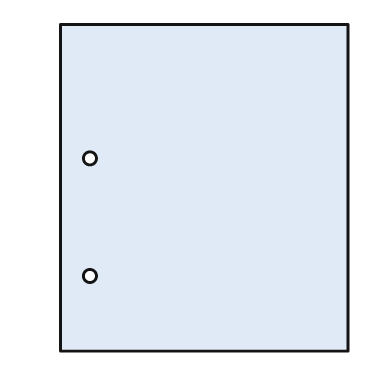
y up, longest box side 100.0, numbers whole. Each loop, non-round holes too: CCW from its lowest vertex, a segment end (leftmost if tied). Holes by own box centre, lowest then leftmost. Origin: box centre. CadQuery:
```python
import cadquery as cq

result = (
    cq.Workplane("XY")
    .moveTo(-44.0, -50.0)
    .lineTo(44.0, -50.0)
    .lineTo(44.0, 50.0)
    .lineTo(-44.0, 50.0)
    .close()
    .moveTo(-35.0, -27.0)
    .circle(2.0)
    .moveTo(-35.0, 9.0)
    .circle(2.0)
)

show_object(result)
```